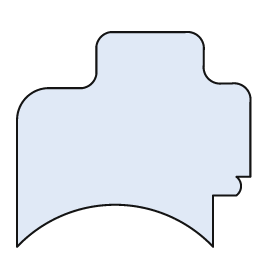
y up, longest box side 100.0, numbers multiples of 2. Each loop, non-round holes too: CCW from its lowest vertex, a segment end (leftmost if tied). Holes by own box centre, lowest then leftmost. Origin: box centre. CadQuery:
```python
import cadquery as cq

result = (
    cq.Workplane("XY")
    .moveTo(-50.0, -46.0)
    .threePointArc((-8.0, -28.0), (34.0, -46.0))
    .lineTo(34.0, -24.0)
    .lineTo(44.0, -24.0)
    .threePointArc((46.0, -20.0), (44.0, -16.0))
    .lineTo(50.0, -16.0)
    .lineTo(50.0, 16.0)
    .threePointArc((48.0, 22.0), (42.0, 24.0))
    .lineTo(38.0, 24.0)
    .threePointArc((32.0, 26.0), (30.0, 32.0))
    .lineTo(30.0, 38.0)
    .threePointArc((28.0, 44.0), (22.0, 46.0))
    .lineTo(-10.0, 46.0)
    .threePointArc((-14.0, 44.0), (-16.0, 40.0))
    .lineTo(-16.0, 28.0)
    .threePointArc((-18.0, 24.0), (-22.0, 22.0))
    .lineTo(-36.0, 22.0)
    .threePointArc((-46.0, 18.0), (-50.0, 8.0))
    .close()
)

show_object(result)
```